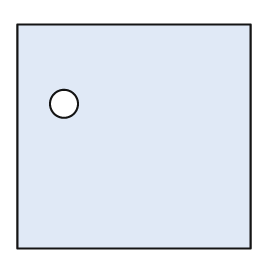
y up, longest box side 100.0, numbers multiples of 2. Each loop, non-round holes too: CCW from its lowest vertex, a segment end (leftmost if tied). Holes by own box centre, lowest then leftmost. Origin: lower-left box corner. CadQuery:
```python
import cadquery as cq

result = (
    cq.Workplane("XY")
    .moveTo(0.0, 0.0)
    .lineTo(100.0, 0.0)
    .lineTo(100.0, 96.0)
    .lineTo(0.0, 96.0)
    .close()
    .moveTo(20.0, 62.0)
    .circle(6.0)
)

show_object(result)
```